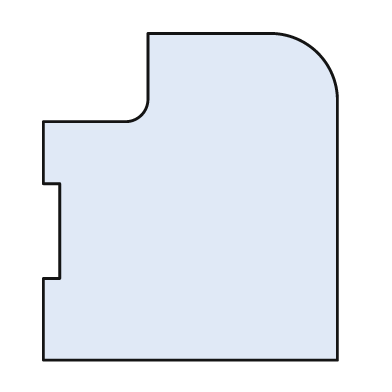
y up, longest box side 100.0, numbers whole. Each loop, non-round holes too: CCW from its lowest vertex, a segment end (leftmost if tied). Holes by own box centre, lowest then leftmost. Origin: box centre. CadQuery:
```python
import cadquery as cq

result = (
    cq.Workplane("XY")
    .moveTo(-45.0, -50.0)
    .lineTo(45.0, -50.0)
    .lineTo(45.0, 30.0)
    .threePointArc((39.0, 44.0), (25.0, 50.0))
    .lineTo(-13.0, 50.0)
    .lineTo(-13.0, 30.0)
    .threePointArc((-15.0, 25.0), (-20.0, 23.0))
    .lineTo(-45.0, 23.0)
    .lineTo(-45.0, 4.0)
    .lineTo(-40.0, 4.0)
    .lineTo(-40.0, -25.0)
    .lineTo(-45.0, -25.0)
    .close()
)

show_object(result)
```